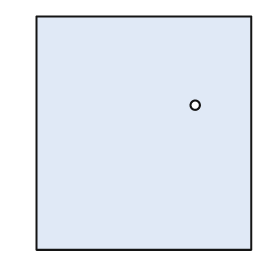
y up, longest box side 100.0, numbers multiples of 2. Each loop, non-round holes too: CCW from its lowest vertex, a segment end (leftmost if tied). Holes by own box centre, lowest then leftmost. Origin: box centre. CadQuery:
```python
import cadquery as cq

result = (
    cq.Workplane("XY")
    .moveTo(-46.0, -50.0)
    .lineTo(46.0, -50.0)
    .lineTo(46.0, 50.0)
    .lineTo(-46.0, 50.0)
    .close()
    .moveTo(22.0, 12.0)
    .circle(2.0)
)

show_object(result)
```